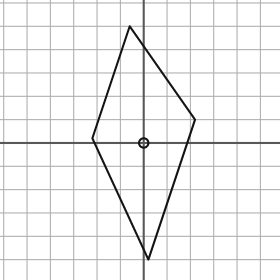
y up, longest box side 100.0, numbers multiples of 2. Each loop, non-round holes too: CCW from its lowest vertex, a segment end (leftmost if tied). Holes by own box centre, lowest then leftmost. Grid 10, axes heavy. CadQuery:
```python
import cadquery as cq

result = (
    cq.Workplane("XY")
    .moveTo(2.0, -50.0)
    .lineTo(22.0, 10.0)
    .lineTo(-6.0, 50.0)
    .lineTo(-22.0, 2.0)
    .close()
    .moveTo(0.0, 0.0)
    .circle(2.0)
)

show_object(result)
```